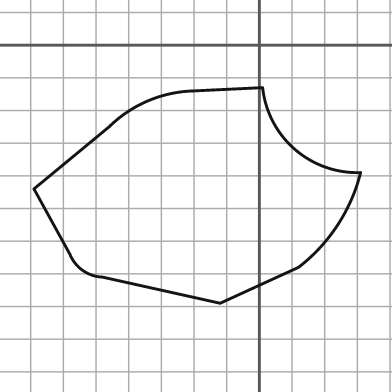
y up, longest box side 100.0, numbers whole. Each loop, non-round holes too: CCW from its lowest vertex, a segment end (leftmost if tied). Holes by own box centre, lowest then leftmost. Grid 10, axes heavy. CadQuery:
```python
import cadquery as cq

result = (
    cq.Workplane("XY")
    .moveTo(-12.0, -79.0)
    .lineTo(12.0, -68.0)
    .threePointArc((24.0, -55.0), (31.0, -39.0))
    .threePointArc((11.0, -32.0), (1.0, -13.0))
    .lineTo(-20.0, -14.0)
    .threePointArc((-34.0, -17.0), (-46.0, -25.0))
    .lineTo(-69.0, -44.0)
    .lineTo(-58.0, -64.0)
    .threePointArc((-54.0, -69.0), (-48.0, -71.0))
    .close()
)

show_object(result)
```